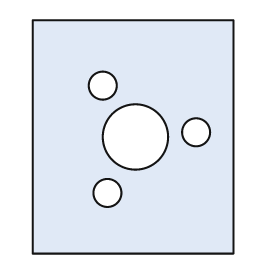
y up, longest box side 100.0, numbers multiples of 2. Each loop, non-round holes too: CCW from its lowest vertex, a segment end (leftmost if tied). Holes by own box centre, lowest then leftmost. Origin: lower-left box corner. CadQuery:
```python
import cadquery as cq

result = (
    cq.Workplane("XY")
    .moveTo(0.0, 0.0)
    .lineTo(86.0, 0.0)
    .lineTo(86.0, 100.0)
    .lineTo(0.0, 100.0)
    .close()
    .moveTo(32.0, 26.0)
    .circle(6.0)
    .moveTo(44.0, 50.0)
    .circle(14.0)
    .moveTo(70.0, 52.0)
    .circle(6.0)
    .moveTo(30.0, 72.0)
    .circle(6.0)
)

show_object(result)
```